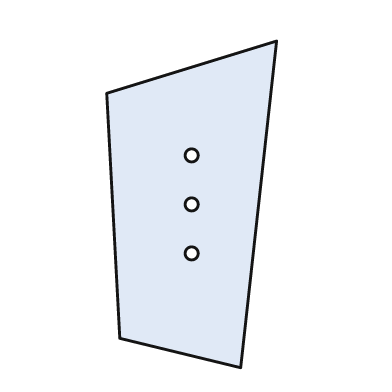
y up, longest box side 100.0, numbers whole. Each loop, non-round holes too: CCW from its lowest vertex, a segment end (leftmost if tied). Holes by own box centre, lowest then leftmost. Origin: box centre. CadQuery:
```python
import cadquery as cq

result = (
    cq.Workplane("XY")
    .moveTo(15.0, -50.0)
    .lineTo(26.0, 50.0)
    .lineTo(-26.0, 34.0)
    .lineTo(-22.0, -41.0)
    .close()
    .moveTo(0.0, -15.0)
    .circle(2.0)
    .moveTo(0.0, 0.0)
    .circle(2.0)
    .moveTo(0.0, 15.0)
    .circle(2.0)
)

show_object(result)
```